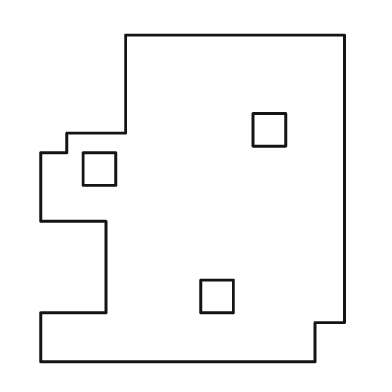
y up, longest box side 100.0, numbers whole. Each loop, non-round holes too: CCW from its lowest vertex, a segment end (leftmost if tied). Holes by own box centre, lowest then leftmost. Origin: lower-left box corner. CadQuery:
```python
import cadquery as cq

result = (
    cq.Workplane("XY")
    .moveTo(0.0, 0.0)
    .lineTo(84.0, 0.0)
    .lineTo(84.0, 12.0)
    .lineTo(93.0, 12.0)
    .lineTo(93.0, 100.0)
    .lineTo(26.0, 100.0)
    .lineTo(26.0, 70.0)
    .lineTo(8.0, 70.0)
    .lineTo(8.0, 64.0)
    .lineTo(0.0, 64.0)
    .lineTo(0.0, 43.0)
    .lineTo(20.0, 43.0)
    .lineTo(20.0, 15.0)
    .lineTo(0.0, 15.0)
    .close()
    .moveTo(49.0, 15.0)
    .lineTo(59.0, 15.0)
    .lineTo(59.0, 25.0)
    .lineTo(49.0, 25.0)
    .close()
    .moveTo(13.0, 54.0)
    .lineTo(23.0, 54.0)
    .lineTo(23.0, 64.0)
    .lineTo(13.0, 64.0)
    .close()
    .moveTo(65.0, 66.0)
    .lineTo(75.0, 66.0)
    .lineTo(75.0, 76.0)
    .lineTo(65.0, 76.0)
    .close()
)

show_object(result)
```